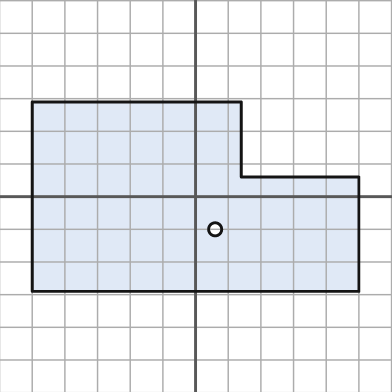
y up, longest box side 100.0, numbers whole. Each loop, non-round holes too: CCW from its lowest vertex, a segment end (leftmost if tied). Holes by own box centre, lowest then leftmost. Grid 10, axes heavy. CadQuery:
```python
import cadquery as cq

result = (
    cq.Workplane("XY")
    .moveTo(-50.0, -29.0)
    .lineTo(50.0, -29.0)
    .lineTo(50.0, 6.0)
    .lineTo(14.0, 6.0)
    .lineTo(14.0, 29.0)
    .lineTo(-50.0, 29.0)
    .close()
    .moveTo(6.0, -10.0)
    .circle(2.0)
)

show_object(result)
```